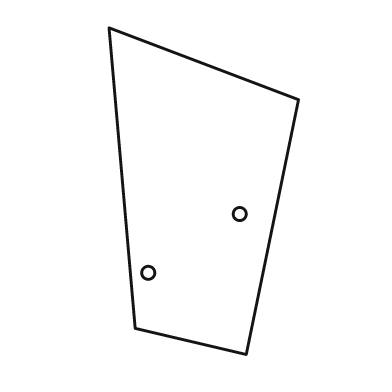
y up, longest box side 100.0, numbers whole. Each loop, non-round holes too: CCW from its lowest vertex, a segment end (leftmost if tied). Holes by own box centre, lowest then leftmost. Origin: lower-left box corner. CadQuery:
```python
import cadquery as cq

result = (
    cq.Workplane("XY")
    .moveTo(42.0, 0.0)
    .lineTo(58.0, 78.0)
    .lineTo(0.0, 100.0)
    .lineTo(8.0, 8.0)
    .close()
    .moveTo(12.0, 25.0)
    .circle(2.0)
    .moveTo(40.0, 43.0)
    .circle(2.0)
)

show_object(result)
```